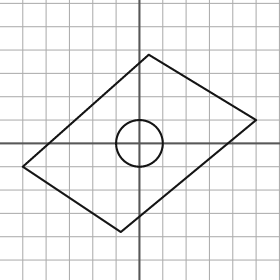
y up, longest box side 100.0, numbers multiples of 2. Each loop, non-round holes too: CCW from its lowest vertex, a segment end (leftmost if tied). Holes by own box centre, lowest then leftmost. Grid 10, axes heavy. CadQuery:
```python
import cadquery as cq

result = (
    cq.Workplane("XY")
    .moveTo(-8.0, -38.0)
    .lineTo(50.0, 10.0)
    .lineTo(4.0, 38.0)
    .lineTo(-50.0, -10.0)
    .close()
    .moveTo(0.0, 0.0)
    .circle(10.0)
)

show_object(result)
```